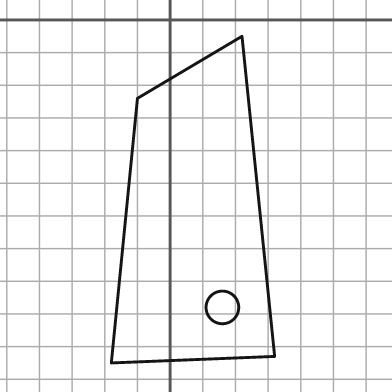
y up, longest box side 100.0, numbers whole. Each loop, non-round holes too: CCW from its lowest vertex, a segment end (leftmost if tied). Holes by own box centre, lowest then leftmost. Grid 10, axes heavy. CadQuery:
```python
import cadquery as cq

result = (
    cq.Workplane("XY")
    .moveTo(-18.0, -105.0)
    .lineTo(32.0, -103.0)
    .lineTo(22.0, -5.0)
    .lineTo(-10.0, -24.0)
    .close()
    .moveTo(16.0, -88.0)
    .circle(5.0)
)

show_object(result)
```